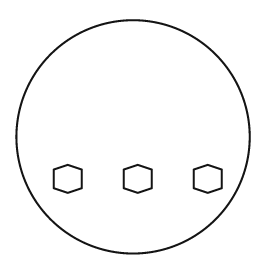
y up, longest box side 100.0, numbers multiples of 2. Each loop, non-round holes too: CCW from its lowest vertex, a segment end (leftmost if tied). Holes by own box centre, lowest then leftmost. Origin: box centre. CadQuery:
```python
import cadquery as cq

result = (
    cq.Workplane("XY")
    .moveTo(0.0, 0.0)
    .circle(50.0)
    .moveTo(-28.0, -24.0)
    .lineTo(-22.0, -22.0)
    .lineTo(-22.0, -14.0)
    .lineTo(-28.0, -12.0)
    .lineTo(-34.0, -14.0)
    .lineTo(-34.0, -22.0)
    .close()
    .moveTo(2.0, -24.0)
    .lineTo(8.0, -22.0)
    .lineTo(8.0, -14.0)
    .lineTo(2.0, -12.0)
    .lineTo(-4.0, -14.0)
    .lineTo(-4.0, -22.0)
    .close()
    .moveTo(32.0, -24.0)
    .lineTo(38.0, -22.0)
    .lineTo(38.0, -14.0)
    .lineTo(32.0, -12.0)
    .lineTo(26.0, -14.0)
    .lineTo(26.0, -22.0)
    .close()
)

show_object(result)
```